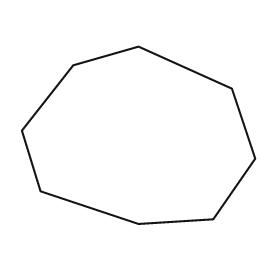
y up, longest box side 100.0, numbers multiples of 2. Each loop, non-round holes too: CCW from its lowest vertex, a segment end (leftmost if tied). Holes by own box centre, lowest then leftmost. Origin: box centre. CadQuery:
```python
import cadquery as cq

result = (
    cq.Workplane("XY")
    .moveTo(0.0, -38.0)
    .lineTo(32.0, -36.0)
    .lineTo(50.0, -10.0)
    .lineTo(40.0, 20.0)
    .lineTo(0.0, 38.0)
    .lineTo(-28.0, 30.0)
    .lineTo(-50.0, 2.0)
    .lineTo(-42.0, -24.0)
    .close()
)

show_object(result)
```